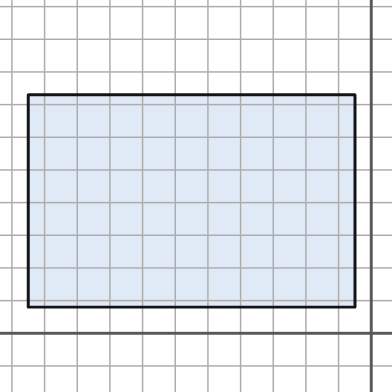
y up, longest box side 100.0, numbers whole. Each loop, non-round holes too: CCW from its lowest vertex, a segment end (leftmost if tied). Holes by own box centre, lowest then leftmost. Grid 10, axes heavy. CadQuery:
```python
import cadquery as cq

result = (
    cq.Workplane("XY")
    .moveTo(-105.0, 8.0)
    .lineTo(-5.0, 8.0)
    .lineTo(-5.0, 73.0)
    .lineTo(-105.0, 73.0)
    .close()
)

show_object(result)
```